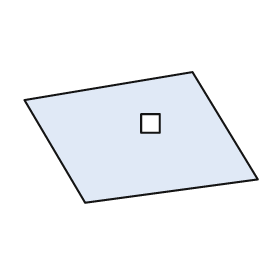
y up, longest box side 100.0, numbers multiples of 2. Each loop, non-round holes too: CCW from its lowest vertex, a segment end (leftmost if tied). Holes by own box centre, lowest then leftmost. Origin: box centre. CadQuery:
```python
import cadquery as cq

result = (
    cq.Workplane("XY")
    .moveTo(-24.0, -28.0)
    .lineTo(50.0, -18.0)
    .lineTo(22.0, 28.0)
    .lineTo(-50.0, 16.0)
    .close()
    .moveTo(0.0, 2.0)
    .lineTo(8.0, 2.0)
    .lineTo(8.0, 10.0)
    .lineTo(0.0, 10.0)
    .close()
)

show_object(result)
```